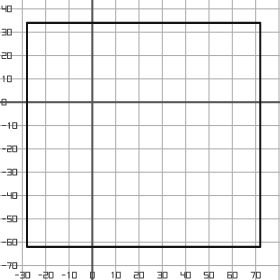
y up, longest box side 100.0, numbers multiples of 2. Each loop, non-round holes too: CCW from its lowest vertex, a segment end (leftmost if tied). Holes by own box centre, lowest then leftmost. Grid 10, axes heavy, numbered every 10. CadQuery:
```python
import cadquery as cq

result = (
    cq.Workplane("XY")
    .moveTo(-28.0, -62.0)
    .lineTo(72.0, -62.0)
    .lineTo(72.0, 34.0)
    .lineTo(-28.0, 34.0)
    .close()
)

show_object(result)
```